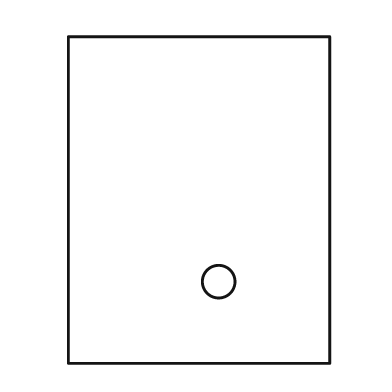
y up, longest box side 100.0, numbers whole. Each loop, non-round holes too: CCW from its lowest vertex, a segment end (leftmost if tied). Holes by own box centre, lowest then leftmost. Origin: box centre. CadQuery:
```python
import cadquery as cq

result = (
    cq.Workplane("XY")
    .moveTo(-40.0, -50.0)
    .lineTo(40.0, -50.0)
    .lineTo(40.0, 50.0)
    .lineTo(-40.0, 50.0)
    .close()
    .moveTo(6.0, -25.0)
    .circle(5.0)
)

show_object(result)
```